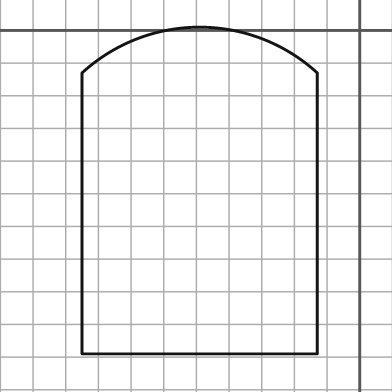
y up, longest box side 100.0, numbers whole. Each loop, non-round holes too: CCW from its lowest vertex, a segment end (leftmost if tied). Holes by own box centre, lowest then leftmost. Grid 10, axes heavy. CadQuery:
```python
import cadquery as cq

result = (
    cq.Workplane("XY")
    .moveTo(-85.0, -99.0)
    .lineTo(-13.0, -99.0)
    .lineTo(-13.0, -13.0)
    .threePointArc((-49.0, 1.0), (-85.0, -13.0))
    .close()
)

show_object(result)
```